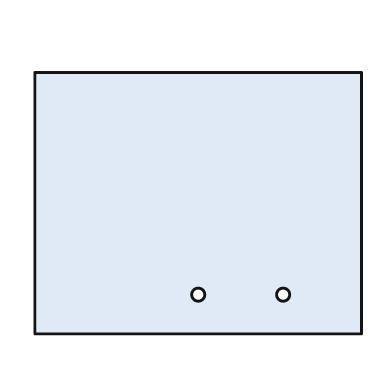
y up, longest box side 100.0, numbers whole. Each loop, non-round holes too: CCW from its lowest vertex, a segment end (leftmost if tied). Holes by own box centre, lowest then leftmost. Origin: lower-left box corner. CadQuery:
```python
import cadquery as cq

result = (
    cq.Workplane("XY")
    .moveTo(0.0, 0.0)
    .lineTo(100.0, 0.0)
    .lineTo(100.0, 80.0)
    .lineTo(0.0, 80.0)
    .close()
    .moveTo(50.0, 12.0)
    .circle(2.0)
    .moveTo(76.0, 12.0)
    .circle(2.0)
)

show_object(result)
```